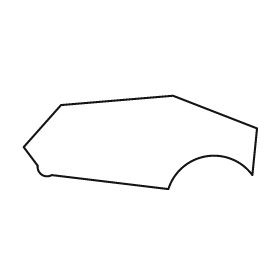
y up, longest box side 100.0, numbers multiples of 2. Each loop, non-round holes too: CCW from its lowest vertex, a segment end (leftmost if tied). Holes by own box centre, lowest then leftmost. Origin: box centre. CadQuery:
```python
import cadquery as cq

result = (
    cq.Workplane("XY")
    .moveTo(12.0, -20.0)
    .threePointArc((28.0, -6.0), (48.0, -14.0))
    .lineTo(50.0, 6.0)
    .lineTo(14.0, 20.0)
    .lineTo(-34.0, 16.0)
    .lineTo(-50.0, -2.0)
    .lineTo(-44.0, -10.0)
    .threePointArc((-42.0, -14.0), (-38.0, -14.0))
    .close()
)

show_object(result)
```